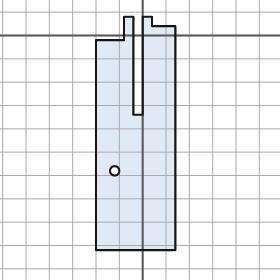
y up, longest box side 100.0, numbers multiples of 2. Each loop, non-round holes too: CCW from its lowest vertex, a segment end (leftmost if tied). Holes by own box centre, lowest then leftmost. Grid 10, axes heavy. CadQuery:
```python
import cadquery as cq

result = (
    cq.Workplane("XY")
    .moveTo(-20.0, -92.0)
    .lineTo(14.0, -92.0)
    .lineTo(14.0, 4.0)
    .lineTo(4.0, 4.0)
    .lineTo(4.0, 8.0)
    .lineTo(0.0, 8.0)
    .lineTo(0.0, -34.0)
    .lineTo(-4.0, -34.0)
    .lineTo(-4.0, 8.0)
    .lineTo(-8.0, 8.0)
    .lineTo(-8.0, -2.0)
    .lineTo(-20.0, -2.0)
    .close()
    .moveTo(-12.0, -58.0)
    .circle(2.0)
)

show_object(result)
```